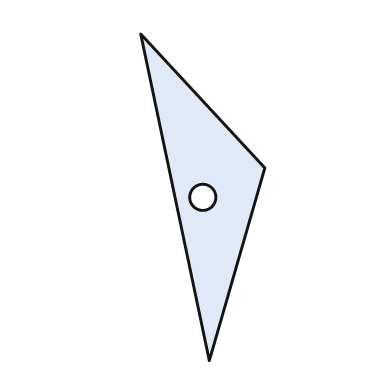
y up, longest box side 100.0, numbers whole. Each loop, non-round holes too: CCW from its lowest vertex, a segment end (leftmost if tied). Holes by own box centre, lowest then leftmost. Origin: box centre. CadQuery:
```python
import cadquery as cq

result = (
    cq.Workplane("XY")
    .moveTo(2.0, -50.0)
    .lineTo(19.0, 9.0)
    .lineTo(-19.0, 50.0)
    .close()
    .moveTo(0.0, 0.0)
    .circle(4.0)
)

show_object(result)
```